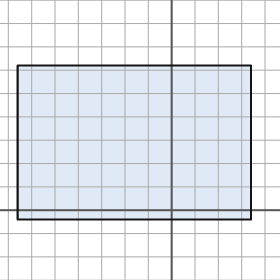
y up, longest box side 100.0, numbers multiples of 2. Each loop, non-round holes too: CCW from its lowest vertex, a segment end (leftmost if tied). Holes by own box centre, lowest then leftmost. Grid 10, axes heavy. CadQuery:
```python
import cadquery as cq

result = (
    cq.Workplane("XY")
    .moveTo(-66.0, -4.0)
    .lineTo(34.0, -4.0)
    .lineTo(34.0, 62.0)
    .lineTo(-66.0, 62.0)
    .close()
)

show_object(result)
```